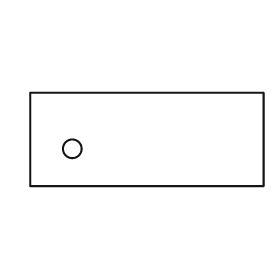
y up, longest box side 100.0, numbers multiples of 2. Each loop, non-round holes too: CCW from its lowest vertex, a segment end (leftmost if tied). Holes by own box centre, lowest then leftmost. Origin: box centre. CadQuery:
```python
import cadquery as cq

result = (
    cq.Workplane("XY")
    .moveTo(-50.0, -20.0)
    .lineTo(50.0, -20.0)
    .lineTo(50.0, 20.0)
    .lineTo(-50.0, 20.0)
    .close()
    .moveTo(-32.0, -4.0)
    .circle(4.0)
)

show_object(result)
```